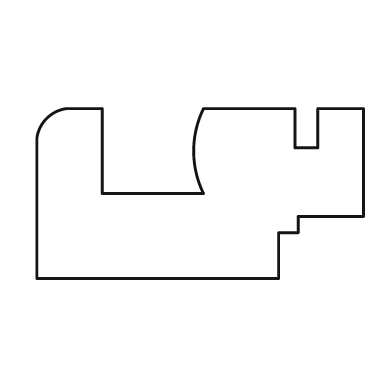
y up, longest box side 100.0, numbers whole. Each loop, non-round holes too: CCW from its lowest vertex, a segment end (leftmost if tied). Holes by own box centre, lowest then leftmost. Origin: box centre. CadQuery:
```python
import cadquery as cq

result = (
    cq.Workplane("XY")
    .moveTo(-50.0, -26.0)
    .lineTo(24.0, -26.0)
    .lineTo(24.0, -12.0)
    .lineTo(30.0, -12.0)
    .lineTo(30.0, -7.0)
    .lineTo(50.0, -7.0)
    .lineTo(50.0, 26.0)
    .lineTo(36.0, 26.0)
    .lineTo(36.0, 14.0)
    .lineTo(29.0, 14.0)
    .lineTo(29.0, 26.0)
    .lineTo(1.0, 26.0)
    .threePointArc((-2.0, 13.0), (1.0, 0.0))
    .lineTo(-30.0, 0.0)
    .lineTo(-30.0, 26.0)
    .lineTo(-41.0, 26.0)
    .threePointArc((-47.0, 23.0), (-50.0, 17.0))
    .close()
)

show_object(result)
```